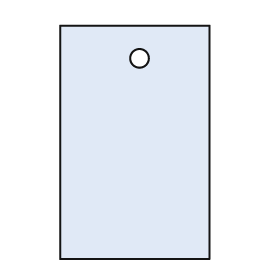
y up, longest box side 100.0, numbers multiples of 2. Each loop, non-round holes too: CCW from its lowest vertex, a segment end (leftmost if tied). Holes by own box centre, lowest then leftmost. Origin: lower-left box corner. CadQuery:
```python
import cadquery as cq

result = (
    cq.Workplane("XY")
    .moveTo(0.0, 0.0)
    .lineTo(64.0, 0.0)
    .lineTo(64.0, 100.0)
    .lineTo(0.0, 100.0)
    .close()
    .moveTo(34.0, 86.0)
    .circle(4.0)
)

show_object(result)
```